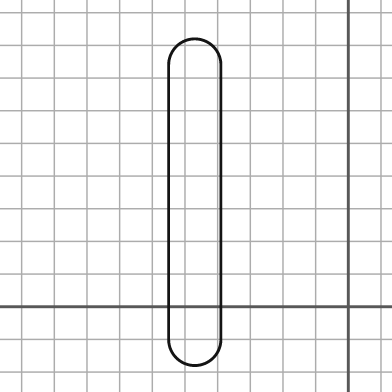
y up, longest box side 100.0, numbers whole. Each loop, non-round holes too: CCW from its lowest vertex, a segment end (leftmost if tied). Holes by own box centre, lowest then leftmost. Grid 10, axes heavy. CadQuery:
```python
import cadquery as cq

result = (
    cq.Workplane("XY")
    .moveTo(-55.0, -10.0)
    .threePointArc((-47.0, -18.0), (-39.0, -10.0))
    .lineTo(-39.0, 74.0)
    .threePointArc((-47.0, 82.0), (-55.0, 74.0))
    .close()
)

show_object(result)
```